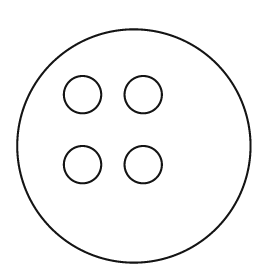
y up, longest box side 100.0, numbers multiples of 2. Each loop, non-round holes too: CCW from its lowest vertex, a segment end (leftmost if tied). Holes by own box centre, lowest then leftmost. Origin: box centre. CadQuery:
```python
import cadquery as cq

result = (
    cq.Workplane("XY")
    .moveTo(0.0, 0.0)
    .circle(50.0)
    .moveTo(-22.0, -8.0)
    .circle(8.0)
    .moveTo(4.0, -8.0)
    .circle(8.0)
    .moveTo(-22.0, 22.0)
    .circle(8.0)
    .moveTo(4.0, 22.0)
    .circle(8.0)
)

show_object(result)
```